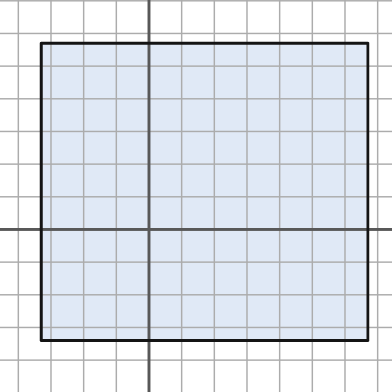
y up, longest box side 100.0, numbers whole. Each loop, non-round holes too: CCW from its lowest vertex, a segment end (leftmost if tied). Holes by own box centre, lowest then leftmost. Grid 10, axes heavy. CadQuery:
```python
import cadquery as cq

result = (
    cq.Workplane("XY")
    .moveTo(-33.0, -34.0)
    .lineTo(67.0, -34.0)
    .lineTo(67.0, 57.0)
    .lineTo(-33.0, 57.0)
    .close()
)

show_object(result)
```